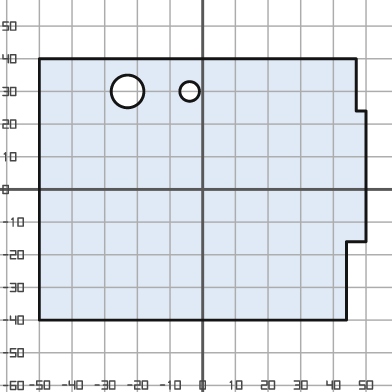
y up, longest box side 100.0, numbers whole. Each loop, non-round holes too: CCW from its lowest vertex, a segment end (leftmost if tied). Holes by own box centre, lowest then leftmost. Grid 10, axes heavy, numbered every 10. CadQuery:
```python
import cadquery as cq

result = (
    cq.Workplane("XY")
    .moveTo(-50.0, -40.0)
    .lineTo(44.0, -40.0)
    .lineTo(44.0, -16.0)
    .lineTo(50.0, -16.0)
    .lineTo(50.0, 24.0)
    .lineTo(47.0, 24.0)
    .lineTo(47.0, 40.0)
    .lineTo(-50.0, 40.0)
    .close()
    .moveTo(-23.0, 30.0)
    .circle(5.0)
    .moveTo(-4.0, 30.0)
    .circle(3.0)
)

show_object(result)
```